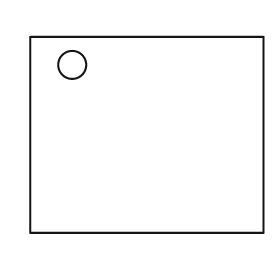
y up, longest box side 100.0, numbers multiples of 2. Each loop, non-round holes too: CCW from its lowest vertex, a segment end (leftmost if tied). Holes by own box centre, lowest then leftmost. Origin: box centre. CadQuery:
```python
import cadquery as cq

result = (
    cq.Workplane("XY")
    .moveTo(-50.0, -42.0)
    .lineTo(50.0, -42.0)
    .lineTo(50.0, 42.0)
    .lineTo(-50.0, 42.0)
    .close()
    .moveTo(-32.0, 30.0)
    .circle(6.0)
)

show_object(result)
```